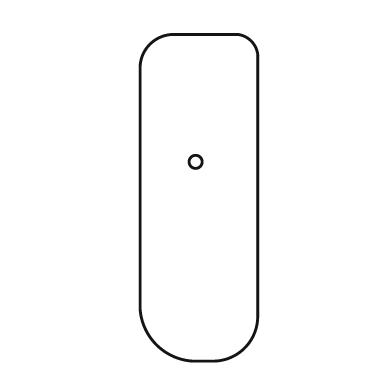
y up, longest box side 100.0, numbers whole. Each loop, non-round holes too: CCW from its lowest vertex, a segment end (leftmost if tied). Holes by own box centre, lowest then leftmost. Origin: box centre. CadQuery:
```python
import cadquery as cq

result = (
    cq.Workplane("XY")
    .moveTo(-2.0, -50.0)
    .lineTo(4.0, -50.0)
    .threePointArc((14.0, -46.0), (18.0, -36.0))
    .lineTo(18.0, 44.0)
    .threePointArc((16.0, 48.0), (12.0, 50.0))
    .lineTo(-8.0, 50.0)
    .threePointArc((-15.0, 47.0), (-18.0, 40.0))
    .lineTo(-18.0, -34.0)
    .threePointArc((-13.0, -45.0), (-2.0, -50.0))
    .close()
    .moveTo(-1.0, 11.0)
    .circle(2.0)
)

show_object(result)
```